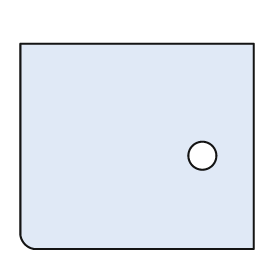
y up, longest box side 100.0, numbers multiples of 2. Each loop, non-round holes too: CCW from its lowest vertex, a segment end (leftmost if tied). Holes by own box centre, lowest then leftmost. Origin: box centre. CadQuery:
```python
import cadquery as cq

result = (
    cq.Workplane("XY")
    .moveTo(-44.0, -44.0)
    .lineTo(50.0, -44.0)
    .lineTo(50.0, 44.0)
    .lineTo(-50.0, 44.0)
    .lineTo(-50.0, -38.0)
    .threePointArc((-48.0, -42.0), (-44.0, -44.0))
    .close()
    .moveTo(28.0, -4.0)
    .circle(6.0)
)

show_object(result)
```